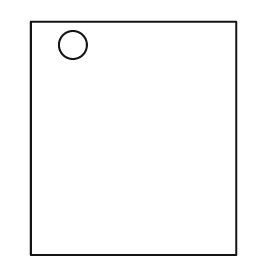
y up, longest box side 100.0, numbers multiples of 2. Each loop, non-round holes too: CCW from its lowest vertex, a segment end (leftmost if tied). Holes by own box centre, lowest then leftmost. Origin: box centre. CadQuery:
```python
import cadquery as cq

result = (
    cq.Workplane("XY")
    .moveTo(-44.0, -50.0)
    .lineTo(44.0, -50.0)
    .lineTo(44.0, 50.0)
    .lineTo(-44.0, 50.0)
    .close()
    .moveTo(-26.0, 40.0)
    .circle(6.0)
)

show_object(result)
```